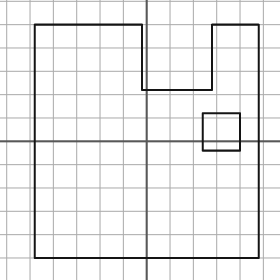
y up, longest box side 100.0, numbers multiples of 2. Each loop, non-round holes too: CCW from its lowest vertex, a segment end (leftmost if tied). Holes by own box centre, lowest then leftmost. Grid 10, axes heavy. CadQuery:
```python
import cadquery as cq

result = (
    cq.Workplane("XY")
    .moveTo(-48.0, -50.0)
    .lineTo(48.0, -50.0)
    .lineTo(48.0, 50.0)
    .lineTo(28.0, 50.0)
    .lineTo(28.0, 22.0)
    .lineTo(-2.0, 22.0)
    .lineTo(-2.0, 50.0)
    .lineTo(-48.0, 50.0)
    .close()
    .moveTo(24.0, -4.0)
    .lineTo(40.0, -4.0)
    .lineTo(40.0, 12.0)
    .lineTo(24.0, 12.0)
    .close()
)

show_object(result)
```